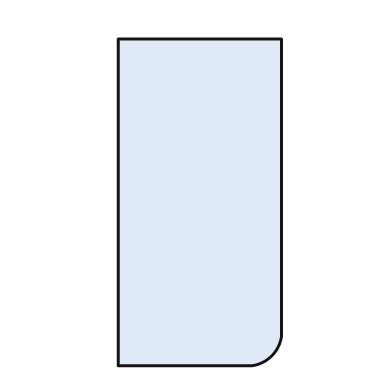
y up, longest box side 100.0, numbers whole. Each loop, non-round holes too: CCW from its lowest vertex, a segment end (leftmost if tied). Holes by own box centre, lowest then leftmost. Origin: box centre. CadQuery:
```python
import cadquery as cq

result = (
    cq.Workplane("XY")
    .moveTo(-25.0, -50.0)
    .lineTo(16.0, -50.0)
    .threePointArc((22.0, -47.0), (25.0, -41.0))
    .lineTo(25.0, 50.0)
    .lineTo(-25.0, 50.0)
    .close()
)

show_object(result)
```